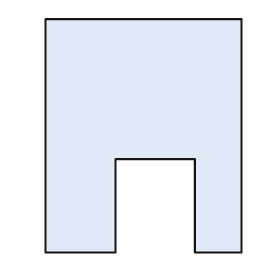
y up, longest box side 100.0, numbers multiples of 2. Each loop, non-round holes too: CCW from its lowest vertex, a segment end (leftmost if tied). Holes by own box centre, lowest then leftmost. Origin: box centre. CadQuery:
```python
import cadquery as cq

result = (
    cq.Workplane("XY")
    .moveTo(-42.0, -50.0)
    .lineTo(-12.0, -50.0)
    .lineTo(-12.0, -10.0)
    .lineTo(22.0, -10.0)
    .lineTo(22.0, -50.0)
    .lineTo(42.0, -50.0)
    .lineTo(42.0, 50.0)
    .lineTo(-42.0, 50.0)
    .close()
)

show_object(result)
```